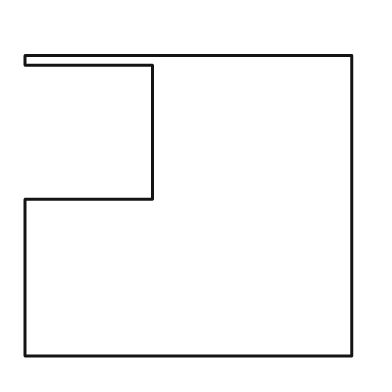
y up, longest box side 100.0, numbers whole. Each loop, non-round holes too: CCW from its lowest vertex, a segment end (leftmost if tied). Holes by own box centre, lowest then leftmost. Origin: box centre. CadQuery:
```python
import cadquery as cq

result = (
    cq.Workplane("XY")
    .moveTo(-50.0, -46.0)
    .lineTo(50.0, -46.0)
    .lineTo(50.0, 46.0)
    .lineTo(-50.0, 46.0)
    .lineTo(-50.0, 43.0)
    .lineTo(-11.0, 43.0)
    .lineTo(-11.0, 2.0)
    .lineTo(-50.0, 2.0)
    .close()
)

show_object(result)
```